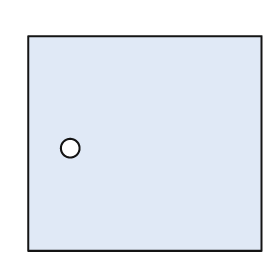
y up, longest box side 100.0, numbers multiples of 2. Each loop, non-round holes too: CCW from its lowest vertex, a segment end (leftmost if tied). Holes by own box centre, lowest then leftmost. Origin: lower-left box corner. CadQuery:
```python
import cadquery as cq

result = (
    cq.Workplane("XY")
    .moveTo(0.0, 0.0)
    .lineTo(100.0, 0.0)
    .lineTo(100.0, 92.0)
    .lineTo(0.0, 92.0)
    .close()
    .moveTo(18.0, 44.0)
    .circle(4.0)
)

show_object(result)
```